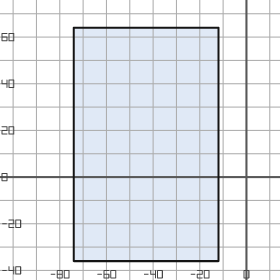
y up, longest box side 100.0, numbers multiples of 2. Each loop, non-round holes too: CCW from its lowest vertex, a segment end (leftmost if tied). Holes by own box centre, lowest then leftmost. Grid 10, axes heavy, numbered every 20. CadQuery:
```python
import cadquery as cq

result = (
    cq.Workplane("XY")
    .moveTo(-74.0, -36.0)
    .lineTo(-12.0, -36.0)
    .lineTo(-12.0, 64.0)
    .lineTo(-74.0, 64.0)
    .close()
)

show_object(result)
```